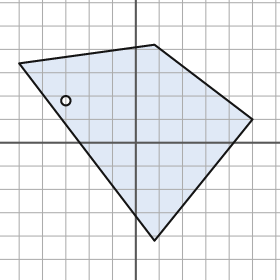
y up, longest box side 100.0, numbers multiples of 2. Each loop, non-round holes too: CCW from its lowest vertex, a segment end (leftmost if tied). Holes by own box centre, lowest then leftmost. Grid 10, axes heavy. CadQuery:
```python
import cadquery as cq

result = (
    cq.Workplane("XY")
    .moveTo(8.0, -42.0)
    .lineTo(50.0, 10.0)
    .lineTo(8.0, 42.0)
    .lineTo(-50.0, 34.0)
    .close()
    .moveTo(-30.0, 18.0)
    .circle(2.0)
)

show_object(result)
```